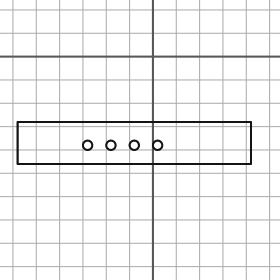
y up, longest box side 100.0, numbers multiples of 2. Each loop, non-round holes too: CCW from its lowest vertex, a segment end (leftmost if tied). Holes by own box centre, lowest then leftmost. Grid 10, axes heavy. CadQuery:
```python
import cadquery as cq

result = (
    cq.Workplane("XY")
    .moveTo(-58.0, -46.0)
    .lineTo(42.0, -46.0)
    .lineTo(42.0, -28.0)
    .lineTo(-58.0, -28.0)
    .close()
    .moveTo(-28.0, -38.0)
    .circle(2.0)
    .moveTo(-18.0, -38.0)
    .circle(2.0)
    .moveTo(-8.0, -38.0)
    .circle(2.0)
    .moveTo(2.0, -38.0)
    .circle(2.0)
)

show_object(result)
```